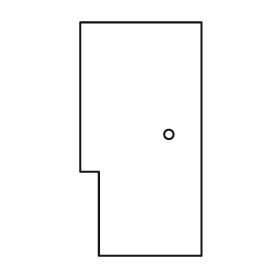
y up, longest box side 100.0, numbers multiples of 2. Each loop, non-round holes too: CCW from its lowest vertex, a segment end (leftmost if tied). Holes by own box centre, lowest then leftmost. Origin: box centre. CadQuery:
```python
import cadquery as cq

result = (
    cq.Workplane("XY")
    .moveTo(-18.0, -50.0)
    .lineTo(26.0, -50.0)
    .lineTo(26.0, 50.0)
    .lineTo(-26.0, 50.0)
    .lineTo(-26.0, -14.0)
    .lineTo(-18.0, -14.0)
    .close()
    .moveTo(12.0, 2.0)
    .circle(2.0)
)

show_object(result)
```